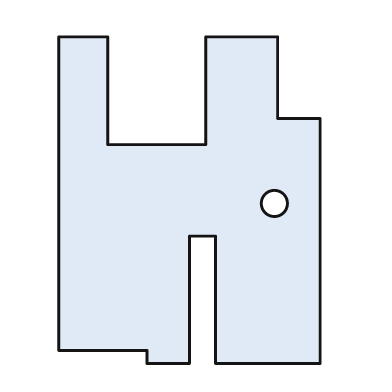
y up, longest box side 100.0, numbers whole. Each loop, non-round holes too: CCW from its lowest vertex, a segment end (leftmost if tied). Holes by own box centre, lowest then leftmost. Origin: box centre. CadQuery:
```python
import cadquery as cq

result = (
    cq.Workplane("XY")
    .moveTo(-13.0, -50.0)
    .lineTo(0.0, -50.0)
    .lineTo(0.0, -11.0)
    .lineTo(8.0, -11.0)
    .lineTo(8.0, -50.0)
    .lineTo(40.0, -50.0)
    .lineTo(40.0, 25.0)
    .lineTo(27.0, 25.0)
    .lineTo(27.0, 50.0)
    .lineTo(5.0, 50.0)
    .lineTo(5.0, 17.0)
    .lineTo(-25.0, 17.0)
    .lineTo(-25.0, 50.0)
    .lineTo(-40.0, 50.0)
    .lineTo(-40.0, -46.0)
    .lineTo(-13.0, -46.0)
    .close()
    .moveTo(26.0, -1.0)
    .circle(4.0)
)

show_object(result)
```